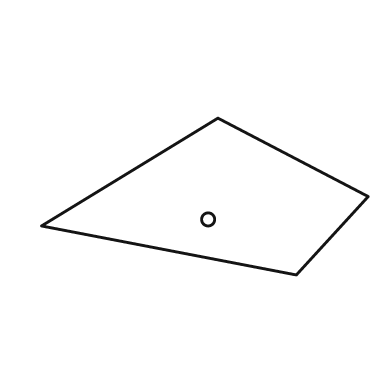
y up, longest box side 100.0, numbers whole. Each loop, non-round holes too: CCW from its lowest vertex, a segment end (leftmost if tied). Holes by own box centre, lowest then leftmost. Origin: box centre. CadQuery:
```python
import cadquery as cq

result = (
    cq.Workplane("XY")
    .moveTo(28.0, -24.0)
    .lineTo(50.0, 0.0)
    .lineTo(4.0, 24.0)
    .lineTo(-50.0, -9.0)
    .close()
    .moveTo(1.0, -7.0)
    .circle(2.0)
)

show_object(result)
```